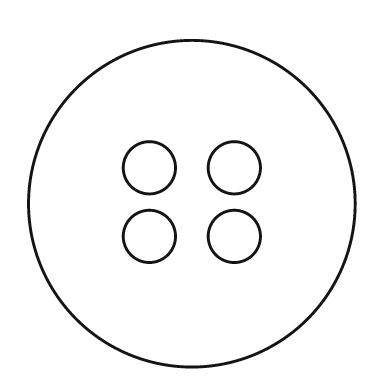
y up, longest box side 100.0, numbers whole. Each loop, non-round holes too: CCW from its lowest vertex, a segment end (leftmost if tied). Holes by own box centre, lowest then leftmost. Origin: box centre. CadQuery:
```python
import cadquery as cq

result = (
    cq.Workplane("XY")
    .moveTo(0.0, 0.0)
    .circle(50.0)
    .moveTo(-13.0, -10.0)
    .circle(8.0)
    .moveTo(13.0, -10.0)
    .circle(8.0)
    .moveTo(-13.0, 11.0)
    .circle(8.0)
    .moveTo(13.0, 11.0)
    .circle(8.0)
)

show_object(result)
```